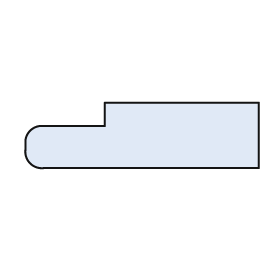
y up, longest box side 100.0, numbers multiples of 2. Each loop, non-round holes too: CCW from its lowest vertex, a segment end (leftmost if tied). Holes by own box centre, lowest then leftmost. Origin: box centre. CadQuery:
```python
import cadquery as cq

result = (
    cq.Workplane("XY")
    .moveTo(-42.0, -14.0)
    .lineTo(50.0, -14.0)
    .lineTo(50.0, 14.0)
    .lineTo(-16.0, 14.0)
    .lineTo(-16.0, 4.0)
    .lineTo(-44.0, 4.0)
    .threePointArc((-48.0, 2.0), (-50.0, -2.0))
    .lineTo(-50.0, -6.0)
    .threePointArc((-48.0, -12.0), (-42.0, -14.0))
    .close()
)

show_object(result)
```